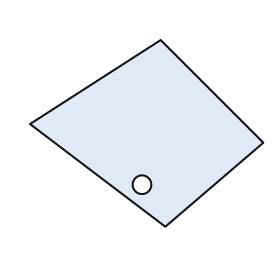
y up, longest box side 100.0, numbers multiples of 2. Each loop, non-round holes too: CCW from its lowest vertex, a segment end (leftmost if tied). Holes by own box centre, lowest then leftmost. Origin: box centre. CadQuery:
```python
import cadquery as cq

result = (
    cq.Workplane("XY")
    .moveTo(8.0, -40.0)
    .lineTo(50.0, -4.0)
    .lineTo(6.0, 40.0)
    .lineTo(-50.0, 4.0)
    .close()
    .moveTo(-2.0, -22.0)
    .circle(4.0)
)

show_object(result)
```